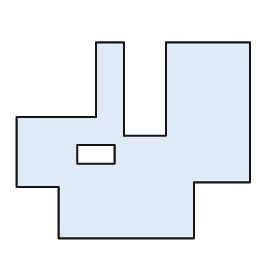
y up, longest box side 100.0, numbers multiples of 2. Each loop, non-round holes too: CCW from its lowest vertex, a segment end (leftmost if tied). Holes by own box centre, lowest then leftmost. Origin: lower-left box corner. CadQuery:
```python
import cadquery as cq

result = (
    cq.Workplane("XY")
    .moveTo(18.0, 0.0)
    .lineTo(76.0, 0.0)
    .lineTo(76.0, 24.0)
    .lineTo(100.0, 24.0)
    .lineTo(100.0, 84.0)
    .lineTo(64.0, 84.0)
    .lineTo(64.0, 44.0)
    .lineTo(46.0, 44.0)
    .lineTo(46.0, 84.0)
    .lineTo(34.0, 84.0)
    .lineTo(34.0, 52.0)
    .lineTo(0.0, 52.0)
    .lineTo(0.0, 22.0)
    .lineTo(18.0, 22.0)
    .close()
    .moveTo(26.0, 32.0)
    .lineTo(42.0, 32.0)
    .lineTo(42.0, 40.0)
    .lineTo(26.0, 40.0)
    .close()
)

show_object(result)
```